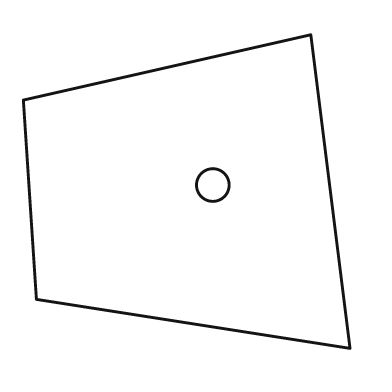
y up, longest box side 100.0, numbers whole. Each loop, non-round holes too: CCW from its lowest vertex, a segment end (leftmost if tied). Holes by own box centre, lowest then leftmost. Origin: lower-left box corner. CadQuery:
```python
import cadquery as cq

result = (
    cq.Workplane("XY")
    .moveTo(100.0, 0.0)
    .lineTo(88.0, 96.0)
    .lineTo(0.0, 76.0)
    .lineTo(4.0, 15.0)
    .close()
    .moveTo(58.0, 50.0)
    .circle(5.0)
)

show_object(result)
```